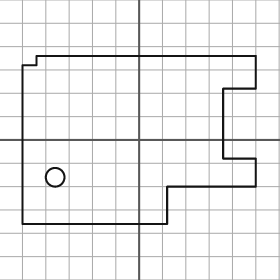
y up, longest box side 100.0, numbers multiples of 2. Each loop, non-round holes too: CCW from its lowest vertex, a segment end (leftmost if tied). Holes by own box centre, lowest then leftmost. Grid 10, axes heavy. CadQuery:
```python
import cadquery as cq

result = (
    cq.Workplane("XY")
    .moveTo(-50.0, -36.0)
    .lineTo(12.0, -36.0)
    .lineTo(12.0, -20.0)
    .lineTo(50.0, -20.0)
    .lineTo(50.0, -8.0)
    .lineTo(36.0, -8.0)
    .lineTo(36.0, 22.0)
    .lineTo(50.0, 22.0)
    .lineTo(50.0, 36.0)
    .lineTo(-44.0, 36.0)
    .lineTo(-44.0, 32.0)
    .lineTo(-50.0, 32.0)
    .close()
    .moveTo(-36.0, -16.0)
    .circle(4.0)
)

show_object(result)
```